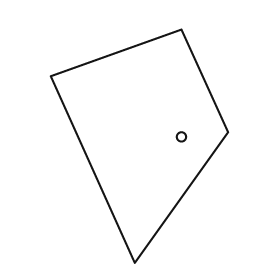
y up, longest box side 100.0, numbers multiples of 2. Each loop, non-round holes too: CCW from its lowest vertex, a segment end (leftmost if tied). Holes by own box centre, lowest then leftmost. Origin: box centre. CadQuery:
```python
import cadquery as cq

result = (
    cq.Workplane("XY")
    .moveTo(-2.0, -50.0)
    .lineTo(38.0, 6.0)
    .lineTo(18.0, 50.0)
    .lineTo(-38.0, 30.0)
    .close()
    .moveTo(18.0, 4.0)
    .circle(2.0)
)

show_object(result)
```